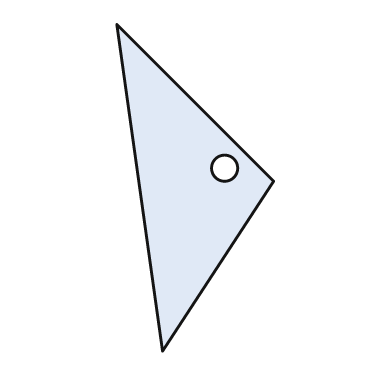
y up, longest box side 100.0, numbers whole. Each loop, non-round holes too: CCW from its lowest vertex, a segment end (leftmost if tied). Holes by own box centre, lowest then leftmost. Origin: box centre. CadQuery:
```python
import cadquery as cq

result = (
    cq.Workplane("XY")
    .moveTo(-10.0, -50.0)
    .lineTo(24.0, 2.0)
    .lineTo(-24.0, 50.0)
    .close()
    .moveTo(9.0, 6.0)
    .circle(4.0)
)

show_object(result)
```